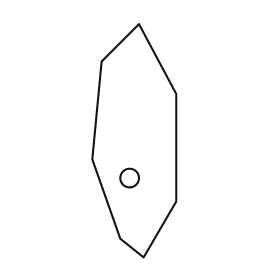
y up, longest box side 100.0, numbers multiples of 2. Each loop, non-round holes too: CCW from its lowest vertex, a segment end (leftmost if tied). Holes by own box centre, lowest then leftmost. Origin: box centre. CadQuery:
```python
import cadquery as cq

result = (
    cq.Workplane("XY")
    .moveTo(4.0, -50.0)
    .lineTo(18.0, -26.0)
    .lineTo(18.0, 20.0)
    .lineTo(2.0, 50.0)
    .lineTo(-14.0, 34.0)
    .lineTo(-18.0, -8.0)
    .lineTo(-6.0, -42.0)
    .close()
    .moveTo(-2.0, -16.0)
    .circle(4.0)
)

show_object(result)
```